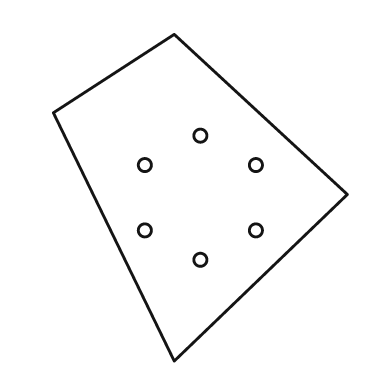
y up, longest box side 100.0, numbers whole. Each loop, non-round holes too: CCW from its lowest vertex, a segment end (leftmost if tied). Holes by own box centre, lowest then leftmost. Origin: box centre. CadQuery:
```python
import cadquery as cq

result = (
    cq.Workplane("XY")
    .moveTo(-8.0, -50.0)
    .lineTo(45.0, 1.0)
    .lineTo(-8.0, 50.0)
    .lineTo(-45.0, 26.0)
    .close()
    .moveTo(0.0, -19.0)
    .circle(2.0)
    .moveTo(-17.0, -10.0)
    .circle(2.0)
    .moveTo(17.0, -10.0)
    .circle(2.0)
    .moveTo(-17.0, 10.0)
    .circle(2.0)
    .moveTo(17.0, 10.0)
    .circle(2.0)
    .moveTo(0.0, 19.0)
    .circle(2.0)
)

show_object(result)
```